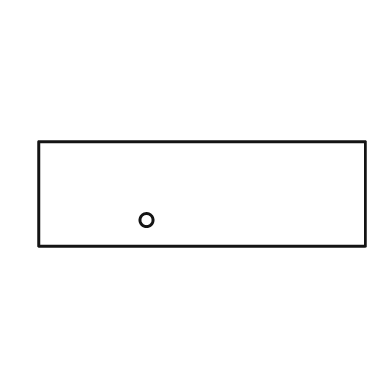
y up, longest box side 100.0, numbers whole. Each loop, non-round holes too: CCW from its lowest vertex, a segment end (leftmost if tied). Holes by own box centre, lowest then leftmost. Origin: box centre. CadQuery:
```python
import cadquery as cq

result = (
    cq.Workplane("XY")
    .moveTo(-50.0, -16.0)
    .lineTo(50.0, -16.0)
    .lineTo(50.0, 16.0)
    .lineTo(-50.0, 16.0)
    .close()
    .moveTo(-17.0, -8.0)
    .circle(2.0)
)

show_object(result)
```